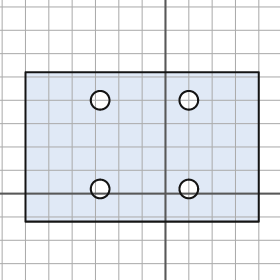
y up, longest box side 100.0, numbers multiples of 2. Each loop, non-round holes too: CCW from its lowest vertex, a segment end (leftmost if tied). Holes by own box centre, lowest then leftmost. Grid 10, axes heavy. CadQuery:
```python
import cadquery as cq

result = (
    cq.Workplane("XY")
    .moveTo(-60.0, -12.0)
    .lineTo(40.0, -12.0)
    .lineTo(40.0, 52.0)
    .lineTo(-60.0, 52.0)
    .close()
    .moveTo(-28.0, 2.0)
    .circle(4.0)
    .moveTo(10.0, 2.0)
    .circle(4.0)
    .moveTo(-28.0, 40.0)
    .circle(4.0)
    .moveTo(10.0, 40.0)
    .circle(4.0)
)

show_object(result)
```